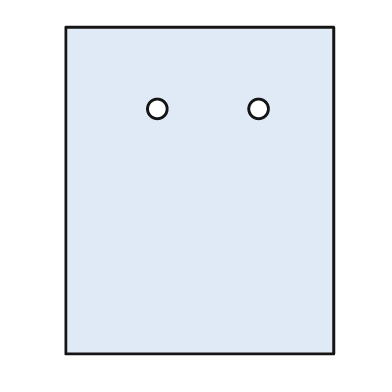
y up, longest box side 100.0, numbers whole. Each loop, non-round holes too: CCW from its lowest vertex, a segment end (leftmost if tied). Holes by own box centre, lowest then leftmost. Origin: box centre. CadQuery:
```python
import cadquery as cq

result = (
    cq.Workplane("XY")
    .moveTo(-41.0, -50.0)
    .lineTo(41.0, -50.0)
    .lineTo(41.0, 50.0)
    .lineTo(-41.0, 50.0)
    .close()
    .moveTo(-13.0, 25.0)
    .circle(3.0)
    .moveTo(18.0, 25.0)
    .circle(3.0)
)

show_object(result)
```